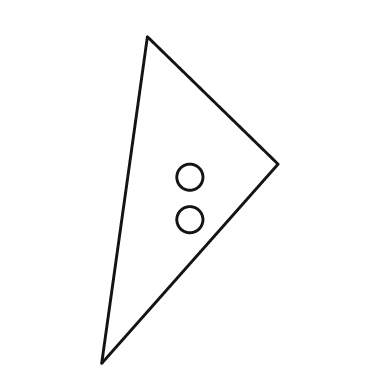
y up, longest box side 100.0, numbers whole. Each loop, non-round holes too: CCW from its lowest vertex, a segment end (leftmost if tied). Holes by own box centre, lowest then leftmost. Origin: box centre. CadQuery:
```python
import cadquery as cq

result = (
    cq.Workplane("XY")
    .moveTo(-27.0, -50.0)
    .lineTo(27.0, 11.0)
    .lineTo(-13.0, 50.0)
    .close()
    .moveTo(0.0, -6.0)
    .circle(4.0)
    .moveTo(0.0, 7.0)
    .circle(4.0)
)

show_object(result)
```